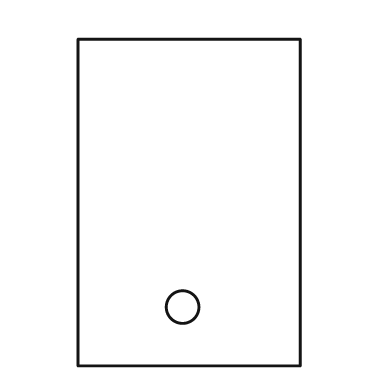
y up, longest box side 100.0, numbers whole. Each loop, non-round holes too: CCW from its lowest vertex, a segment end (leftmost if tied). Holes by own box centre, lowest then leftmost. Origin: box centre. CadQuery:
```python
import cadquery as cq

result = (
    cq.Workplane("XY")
    .moveTo(-34.0, -50.0)
    .lineTo(34.0, -50.0)
    .lineTo(34.0, 50.0)
    .lineTo(-34.0, 50.0)
    .close()
    .moveTo(-2.0, -32.0)
    .circle(5.0)
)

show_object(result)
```